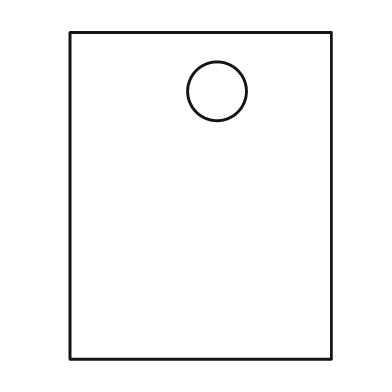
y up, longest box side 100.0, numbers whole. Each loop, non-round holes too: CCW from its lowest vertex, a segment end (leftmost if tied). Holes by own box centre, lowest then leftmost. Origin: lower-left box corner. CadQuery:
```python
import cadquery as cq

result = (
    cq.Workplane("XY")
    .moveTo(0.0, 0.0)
    .lineTo(80.0, 0.0)
    .lineTo(80.0, 100.0)
    .lineTo(0.0, 100.0)
    .close()
    .moveTo(45.0, 82.0)
    .circle(9.0)
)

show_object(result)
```